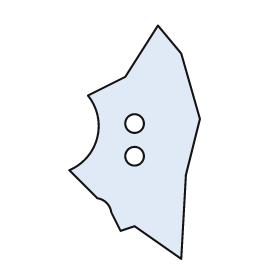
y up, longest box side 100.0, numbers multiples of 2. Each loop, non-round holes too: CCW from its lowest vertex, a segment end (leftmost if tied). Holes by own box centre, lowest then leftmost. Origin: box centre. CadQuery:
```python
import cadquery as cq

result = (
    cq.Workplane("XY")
    .moveTo(20.0, -50.0)
    .lineTo(22.0, -14.0)
    .lineTo(28.0, 10.0)
    .lineTo(20.0, 38.0)
    .lineTo(10.0, 50.0)
    .lineTo(-4.0, 28.0)
    .lineTo(-20.0, 20.0)
    .threePointArc((-16.0, 2.0), (-28.0, -12.0))
    .lineTo(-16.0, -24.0)
    .threePointArc((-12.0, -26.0), (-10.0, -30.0))
    .lineTo(-6.0, -38.0)
    .lineTo(0.0, -36.0)
    .close()
    .moveTo(0.0, -6.0)
    .circle(4.0)
    .moveTo(0.0, 8.0)
    .circle(4.0)
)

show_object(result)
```